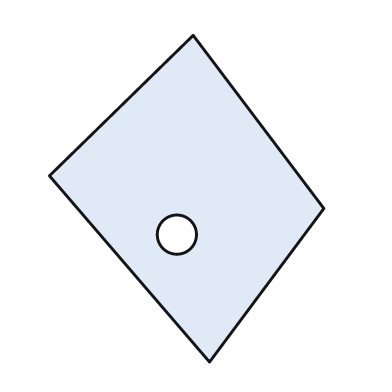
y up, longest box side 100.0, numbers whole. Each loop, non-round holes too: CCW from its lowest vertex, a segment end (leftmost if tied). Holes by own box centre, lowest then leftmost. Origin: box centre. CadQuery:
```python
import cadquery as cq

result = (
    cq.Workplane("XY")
    .moveTo(7.0, -50.0)
    .lineTo(42.0, -3.0)
    .lineTo(2.0, 50.0)
    .lineTo(-42.0, 7.0)
    .close()
    .moveTo(-3.0, -11.0)
    .circle(6.0)
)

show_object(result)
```